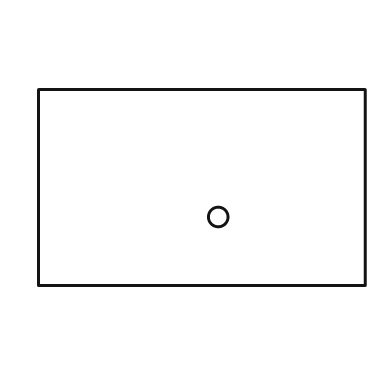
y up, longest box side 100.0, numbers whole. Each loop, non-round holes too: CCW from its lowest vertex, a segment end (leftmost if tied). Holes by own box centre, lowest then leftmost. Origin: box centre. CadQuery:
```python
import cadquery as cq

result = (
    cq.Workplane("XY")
    .moveTo(-50.0, -30.0)
    .lineTo(50.0, -30.0)
    .lineTo(50.0, 30.0)
    .lineTo(-50.0, 30.0)
    .close()
    .moveTo(5.0, -9.0)
    .circle(3.0)
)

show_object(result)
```